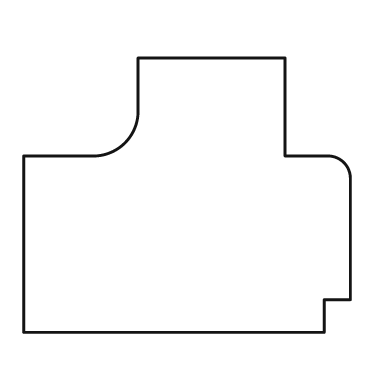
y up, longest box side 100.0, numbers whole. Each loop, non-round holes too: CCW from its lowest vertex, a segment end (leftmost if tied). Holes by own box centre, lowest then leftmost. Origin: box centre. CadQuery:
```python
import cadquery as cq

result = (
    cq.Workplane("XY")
    .moveTo(-50.0, -42.0)
    .lineTo(42.0, -42.0)
    .lineTo(42.0, -32.0)
    .lineTo(50.0, -32.0)
    .lineTo(50.0, 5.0)
    .threePointArc((48.0, 10.0), (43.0, 12.0))
    .lineTo(30.0, 12.0)
    .lineTo(30.0, 42.0)
    .lineTo(-15.0, 42.0)
    .lineTo(-15.0, 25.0)
    .threePointArc((-19.0, 16.0), (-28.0, 12.0))
    .lineTo(-50.0, 12.0)
    .close()
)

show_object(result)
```